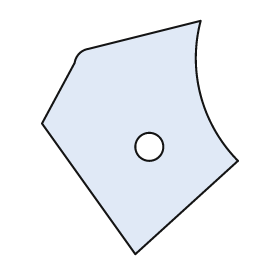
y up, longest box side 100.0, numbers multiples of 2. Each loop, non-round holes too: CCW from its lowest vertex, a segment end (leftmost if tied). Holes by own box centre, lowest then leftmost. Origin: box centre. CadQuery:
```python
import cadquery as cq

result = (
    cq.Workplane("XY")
    .moveTo(-2.0, -50.0)
    .lineTo(42.0, -10.0)
    .threePointArc((26.0, 18.0), (26.0, 50.0))
    .lineTo(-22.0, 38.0)
    .threePointArc((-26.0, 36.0), (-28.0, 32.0))
    .lineTo(-42.0, 6.0)
    .close()
    .moveTo(4.0, -4.0)
    .circle(6.0)
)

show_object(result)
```